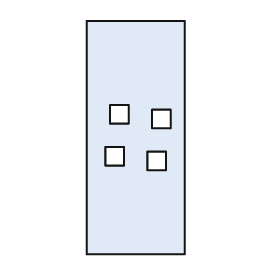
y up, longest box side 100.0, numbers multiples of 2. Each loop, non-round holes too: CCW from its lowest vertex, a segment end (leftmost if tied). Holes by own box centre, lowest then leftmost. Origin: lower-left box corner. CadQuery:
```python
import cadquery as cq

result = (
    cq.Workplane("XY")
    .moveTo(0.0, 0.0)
    .lineTo(42.0, 0.0)
    .lineTo(42.0, 100.0)
    .lineTo(0.0, 100.0)
    .close()
    .moveTo(26.0, 36.0)
    .lineTo(34.0, 36.0)
    .lineTo(34.0, 44.0)
    .lineTo(26.0, 44.0)
    .close()
    .moveTo(8.0, 38.0)
    .lineTo(16.0, 38.0)
    .lineTo(16.0, 46.0)
    .lineTo(8.0, 46.0)
    .close()
    .moveTo(28.0, 54.0)
    .lineTo(36.0, 54.0)
    .lineTo(36.0, 62.0)
    .lineTo(28.0, 62.0)
    .close()
    .moveTo(10.0, 56.0)
    .lineTo(18.0, 56.0)
    .lineTo(18.0, 64.0)
    .lineTo(10.0, 64.0)
    .close()
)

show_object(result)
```